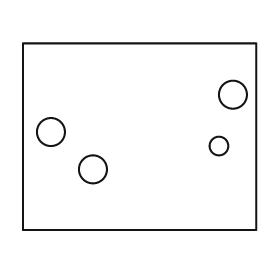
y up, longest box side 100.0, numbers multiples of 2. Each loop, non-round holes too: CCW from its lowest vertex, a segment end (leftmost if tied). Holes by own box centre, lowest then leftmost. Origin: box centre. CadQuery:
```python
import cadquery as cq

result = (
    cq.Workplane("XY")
    .moveTo(-50.0, -40.0)
    .lineTo(50.0, -40.0)
    .lineTo(50.0, 40.0)
    .lineTo(-50.0, 40.0)
    .close()
    .moveTo(-20.0, -14.0)
    .circle(6.0)
    .moveTo(34.0, -4.0)
    .circle(4.0)
    .moveTo(-38.0, 2.0)
    .circle(6.0)
    .moveTo(40.0, 18.0)
    .circle(6.0)
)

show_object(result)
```